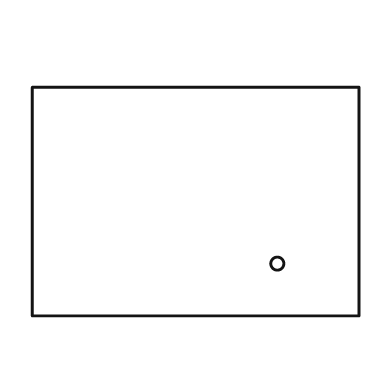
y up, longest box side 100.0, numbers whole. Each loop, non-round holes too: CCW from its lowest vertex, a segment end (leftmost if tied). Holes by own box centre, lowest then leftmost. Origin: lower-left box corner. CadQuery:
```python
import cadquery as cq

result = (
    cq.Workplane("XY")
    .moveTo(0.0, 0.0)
    .lineTo(100.0, 0.0)
    .lineTo(100.0, 70.0)
    .lineTo(0.0, 70.0)
    .close()
    .moveTo(75.0, 16.0)
    .circle(2.0)
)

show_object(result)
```